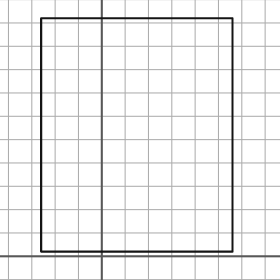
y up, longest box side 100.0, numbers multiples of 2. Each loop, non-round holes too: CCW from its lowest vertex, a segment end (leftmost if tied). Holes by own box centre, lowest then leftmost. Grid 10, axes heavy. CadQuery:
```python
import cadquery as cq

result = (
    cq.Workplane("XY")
    .moveTo(-26.0, 2.0)
    .lineTo(56.0, 2.0)
    .lineTo(56.0, 102.0)
    .lineTo(-26.0, 102.0)
    .close()
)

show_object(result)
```